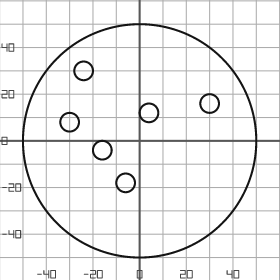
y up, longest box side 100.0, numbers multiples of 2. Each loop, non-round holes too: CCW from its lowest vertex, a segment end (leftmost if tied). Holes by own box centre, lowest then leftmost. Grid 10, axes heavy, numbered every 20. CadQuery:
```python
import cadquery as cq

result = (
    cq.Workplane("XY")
    .moveTo(0.0, 0.0)
    .circle(50.0)
    .moveTo(-6.0, -18.0)
    .circle(4.0)
    .moveTo(-16.0, -4.0)
    .circle(4.0)
    .moveTo(-30.0, 8.0)
    .circle(4.0)
    .moveTo(4.0, 12.0)
    .circle(4.0)
    .moveTo(30.0, 16.0)
    .circle(4.0)
    .moveTo(-24.0, 30.0)
    .circle(4.0)
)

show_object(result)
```